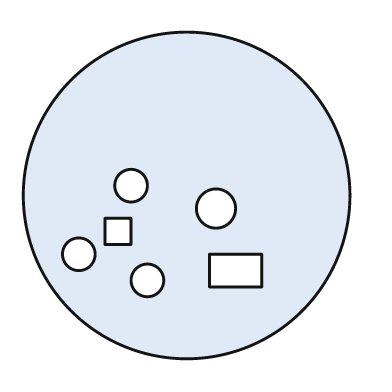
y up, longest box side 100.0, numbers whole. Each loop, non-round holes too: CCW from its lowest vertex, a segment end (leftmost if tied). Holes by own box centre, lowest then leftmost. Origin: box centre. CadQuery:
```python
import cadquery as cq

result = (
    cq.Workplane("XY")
    .moveTo(0.0, 0.0)
    .circle(50.0)
    .moveTo(-12.0, -26.0)
    .circle(5.0)
    .moveTo(7.0, -28.0)
    .lineTo(23.0, -28.0)
    .lineTo(23.0, -18.0)
    .lineTo(7.0, -18.0)
    .close()
    .moveTo(-33.0, -18.0)
    .circle(5.0)
    .moveTo(-25.0, -15.0)
    .lineTo(-17.0, -15.0)
    .lineTo(-17.0, -7.0)
    .lineTo(-25.0, -7.0)
    .close()
    .moveTo(9.0, -4.0)
    .circle(6.0)
    .moveTo(-17.0, 3.0)
    .circle(5.0)
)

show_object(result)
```